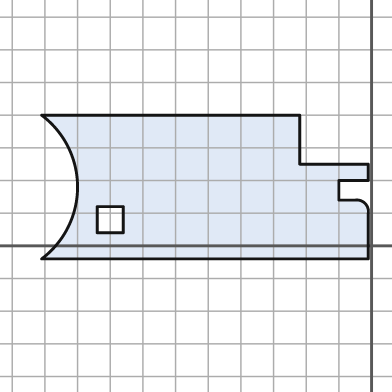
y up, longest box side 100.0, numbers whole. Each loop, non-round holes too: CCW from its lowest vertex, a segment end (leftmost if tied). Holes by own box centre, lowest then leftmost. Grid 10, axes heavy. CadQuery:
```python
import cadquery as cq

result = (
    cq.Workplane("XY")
    .moveTo(-101.0, -4.0)
    .lineTo(-1.0, -4.0)
    .lineTo(-1.0, 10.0)
    .threePointArc((-2.0, 13.0), (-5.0, 14.0))
    .lineTo(-10.0, 14.0)
    .lineTo(-10.0, 20.0)
    .lineTo(-1.0, 20.0)
    .lineTo(-1.0, 25.0)
    .lineTo(-22.0, 25.0)
    .lineTo(-22.0, 40.0)
    .lineTo(-101.0, 40.0)
    .threePointArc((-90.0, 18.0), (-101.0, -4.0))
    .close()
    .moveTo(-84.0, 4.0)
    .lineTo(-76.0, 4.0)
    .lineTo(-76.0, 12.0)
    .lineTo(-84.0, 12.0)
    .close()
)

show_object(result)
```